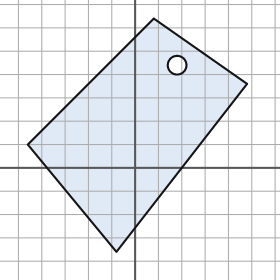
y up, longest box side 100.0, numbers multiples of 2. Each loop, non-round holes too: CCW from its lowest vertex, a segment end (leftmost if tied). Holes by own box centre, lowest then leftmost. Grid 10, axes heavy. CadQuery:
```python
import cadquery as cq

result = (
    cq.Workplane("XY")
    .moveTo(-8.0, -36.0)
    .lineTo(48.0, 36.0)
    .lineTo(8.0, 64.0)
    .lineTo(-46.0, 10.0)
    .close()
    .moveTo(18.0, 44.0)
    .circle(4.0)
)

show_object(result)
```